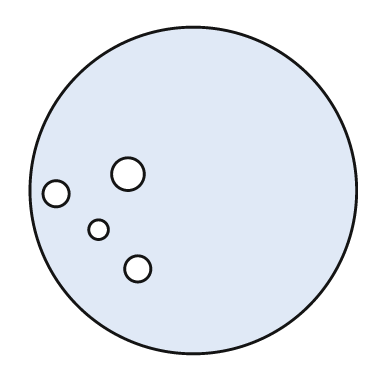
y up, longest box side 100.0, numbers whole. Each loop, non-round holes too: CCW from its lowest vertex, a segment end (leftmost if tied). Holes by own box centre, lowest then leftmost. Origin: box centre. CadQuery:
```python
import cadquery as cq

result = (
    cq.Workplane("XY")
    .moveTo(0.0, 0.0)
    .circle(50.0)
    .moveTo(-17.0, -24.0)
    .circle(4.0)
    .moveTo(-29.0, -12.0)
    .circle(3.0)
    .moveTo(-42.0, -1.0)
    .circle(4.0)
    .moveTo(-20.0, 5.0)
    .circle(5.0)
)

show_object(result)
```